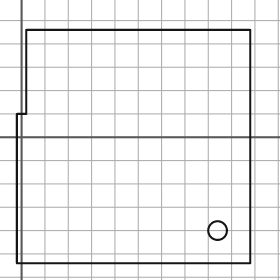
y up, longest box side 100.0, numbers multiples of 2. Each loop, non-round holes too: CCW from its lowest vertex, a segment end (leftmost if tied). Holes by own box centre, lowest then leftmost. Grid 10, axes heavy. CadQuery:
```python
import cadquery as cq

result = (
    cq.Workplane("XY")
    .moveTo(-2.0, -54.0)
    .lineTo(98.0, -54.0)
    .lineTo(98.0, 46.0)
    .lineTo(2.0, 46.0)
    .lineTo(2.0, 10.0)
    .lineTo(-2.0, 10.0)
    .close()
    .moveTo(84.0, -40.0)
    .circle(4.0)
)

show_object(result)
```